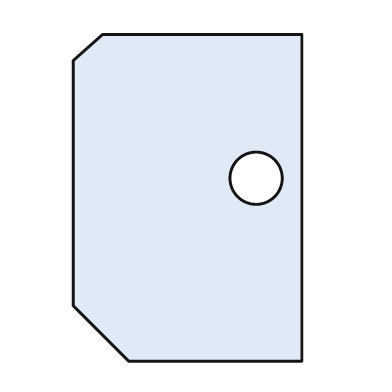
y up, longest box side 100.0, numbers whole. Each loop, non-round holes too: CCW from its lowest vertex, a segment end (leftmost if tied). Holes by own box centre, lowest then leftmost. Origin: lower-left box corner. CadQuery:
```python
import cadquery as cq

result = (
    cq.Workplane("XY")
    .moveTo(17.0, 0.0)
    .lineTo(70.0, 0.0)
    .lineTo(70.0, 100.0)
    .lineTo(9.0, 100.0)
    .lineTo(0.0, 92.0)
    .lineTo(0.0, 17.0)
    .close()
    .moveTo(56.0, 56.0)
    .circle(8.0)
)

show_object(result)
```